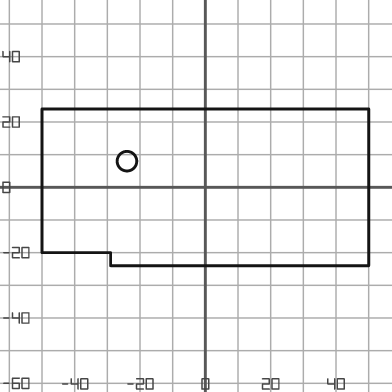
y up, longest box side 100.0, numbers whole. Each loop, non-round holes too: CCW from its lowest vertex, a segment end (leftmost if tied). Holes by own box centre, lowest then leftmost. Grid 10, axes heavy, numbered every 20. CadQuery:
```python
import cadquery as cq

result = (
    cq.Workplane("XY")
    .moveTo(-29.0, -24.0)
    .lineTo(50.0, -24.0)
    .lineTo(50.0, 24.0)
    .lineTo(-50.0, 24.0)
    .lineTo(-50.0, -20.0)
    .lineTo(-29.0, -20.0)
    .close()
    .moveTo(-24.0, 8.0)
    .circle(3.0)
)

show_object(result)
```